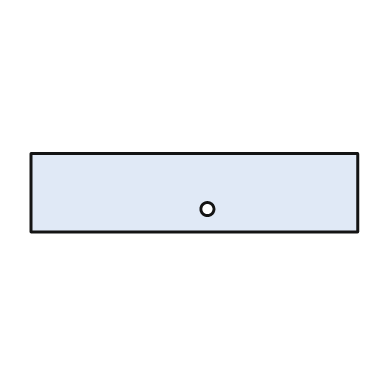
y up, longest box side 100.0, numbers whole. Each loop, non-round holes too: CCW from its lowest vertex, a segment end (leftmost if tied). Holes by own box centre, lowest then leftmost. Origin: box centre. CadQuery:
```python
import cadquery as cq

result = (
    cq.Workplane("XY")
    .moveTo(-50.0, -12.0)
    .lineTo(50.0, -12.0)
    .lineTo(50.0, 12.0)
    .lineTo(-50.0, 12.0)
    .close()
    .moveTo(4.0, -5.0)
    .circle(2.0)
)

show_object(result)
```